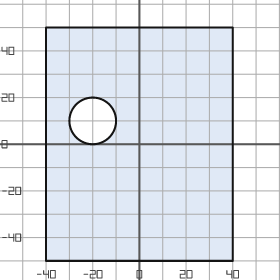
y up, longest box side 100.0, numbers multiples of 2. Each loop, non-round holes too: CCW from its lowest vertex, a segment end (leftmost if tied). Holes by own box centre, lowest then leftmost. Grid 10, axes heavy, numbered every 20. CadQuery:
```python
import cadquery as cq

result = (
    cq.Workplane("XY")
    .moveTo(-40.0, -50.0)
    .lineTo(40.0, -50.0)
    .lineTo(40.0, 50.0)
    .lineTo(-40.0, 50.0)
    .close()
    .moveTo(-20.0, 10.0)
    .circle(10.0)
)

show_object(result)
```